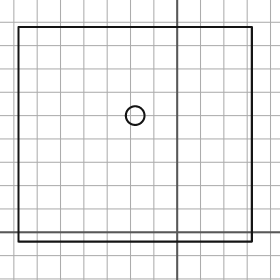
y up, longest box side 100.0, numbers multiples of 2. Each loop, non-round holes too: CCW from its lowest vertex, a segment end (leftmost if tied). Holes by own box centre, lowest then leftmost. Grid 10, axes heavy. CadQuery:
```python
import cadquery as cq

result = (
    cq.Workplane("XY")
    .moveTo(-68.0, -4.0)
    .lineTo(32.0, -4.0)
    .lineTo(32.0, 88.0)
    .lineTo(-68.0, 88.0)
    .close()
    .moveTo(-18.0, 50.0)
    .circle(4.0)
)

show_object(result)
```